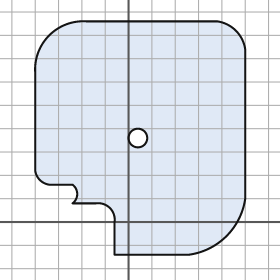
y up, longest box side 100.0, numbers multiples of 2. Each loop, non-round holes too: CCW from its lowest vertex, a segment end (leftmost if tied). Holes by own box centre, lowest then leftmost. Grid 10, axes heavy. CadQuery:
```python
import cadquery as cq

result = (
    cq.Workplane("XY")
    .moveTo(-6.0, -14.0)
    .lineTo(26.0, -14.0)
    .threePointArc((42.0, -6.0), (50.0, 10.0))
    .lineTo(50.0, 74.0)
    .threePointArc((46.0, 82.0), (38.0, 86.0))
    .lineTo(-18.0, 86.0)
    .threePointArc((-34.0, 80.0), (-40.0, 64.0))
    .lineTo(-40.0, 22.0)
    .threePointArc((-38.0, 18.0), (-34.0, 16.0))
    .lineTo(-24.0, 16.0)
    .threePointArc((-22.0, 12.0), (-24.0, 8.0))
    .lineTo(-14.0, 8.0)
    .threePointArc((-8.0, 6.0), (-6.0, 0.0))
    .close()
    .moveTo(4.0, 36.0)
    .circle(4.0)
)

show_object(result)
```